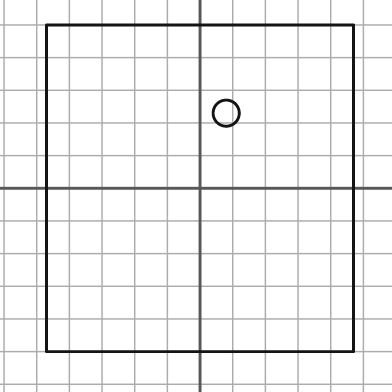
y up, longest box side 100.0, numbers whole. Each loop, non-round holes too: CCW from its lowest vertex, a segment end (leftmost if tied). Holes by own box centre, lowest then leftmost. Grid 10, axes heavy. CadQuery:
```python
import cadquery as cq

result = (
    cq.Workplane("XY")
    .moveTo(-47.0, -50.0)
    .lineTo(47.0, -50.0)
    .lineTo(47.0, 50.0)
    .lineTo(-47.0, 50.0)
    .close()
    .moveTo(8.0, 23.0)
    .circle(4.0)
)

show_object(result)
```